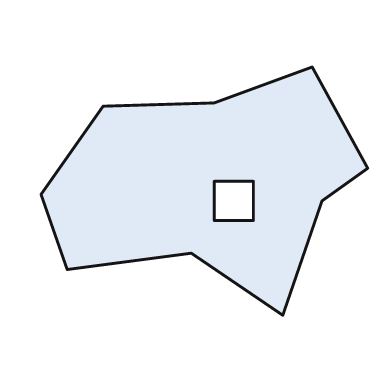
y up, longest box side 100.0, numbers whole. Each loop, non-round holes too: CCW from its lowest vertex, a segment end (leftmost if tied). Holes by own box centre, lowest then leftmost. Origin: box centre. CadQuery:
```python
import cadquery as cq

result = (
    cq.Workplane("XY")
    .moveTo(24.0, -38.0)
    .lineTo(36.0, -3.0)
    .lineTo(50.0, 7.0)
    .lineTo(33.0, 38.0)
    .lineTo(3.0, 27.0)
    .lineTo(-31.0, 26.0)
    .lineTo(-50.0, -1.0)
    .lineTo(-42.0, -24.0)
    .lineTo(-4.0, -19.0)
    .close()
    .moveTo(3.0, -9.0)
    .lineTo(15.0, -9.0)
    .lineTo(15.0, 3.0)
    .lineTo(3.0, 3.0)
    .close()
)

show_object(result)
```